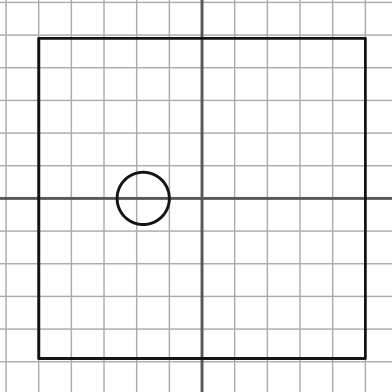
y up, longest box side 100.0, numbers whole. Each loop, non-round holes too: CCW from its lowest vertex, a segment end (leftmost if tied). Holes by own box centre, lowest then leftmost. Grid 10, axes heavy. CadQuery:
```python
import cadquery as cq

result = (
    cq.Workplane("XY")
    .moveTo(-50.0, -49.0)
    .lineTo(50.0, -49.0)
    .lineTo(50.0, 49.0)
    .lineTo(-50.0, 49.0)
    .close()
    .moveTo(-18.0, 0.0)
    .circle(8.0)
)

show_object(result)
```